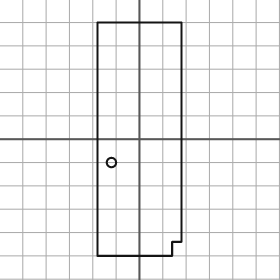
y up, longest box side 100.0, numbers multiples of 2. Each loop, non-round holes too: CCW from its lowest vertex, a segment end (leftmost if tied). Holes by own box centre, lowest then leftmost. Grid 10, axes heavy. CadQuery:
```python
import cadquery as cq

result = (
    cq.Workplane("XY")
    .moveTo(-18.0, -50.0)
    .lineTo(14.0, -50.0)
    .lineTo(14.0, -44.0)
    .lineTo(18.0, -44.0)
    .lineTo(18.0, 50.0)
    .lineTo(-18.0, 50.0)
    .close()
    .moveTo(-12.0, -10.0)
    .circle(2.0)
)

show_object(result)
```